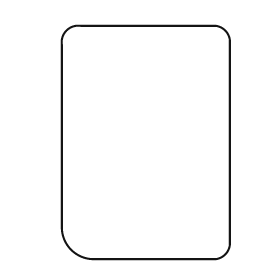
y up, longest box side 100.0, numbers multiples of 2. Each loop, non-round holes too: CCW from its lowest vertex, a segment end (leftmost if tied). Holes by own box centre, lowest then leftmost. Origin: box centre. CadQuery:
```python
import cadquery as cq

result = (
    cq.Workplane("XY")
    .moveTo(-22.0, -50.0)
    .lineTo(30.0, -50.0)
    .threePointArc((34.0, -48.0), (36.0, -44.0))
    .lineTo(36.0, 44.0)
    .threePointArc((34.0, 48.0), (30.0, 50.0))
    .lineTo(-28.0, 50.0)
    .threePointArc((-34.0, 48.0), (-36.0, 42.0))
    .lineTo(-36.0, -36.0)
    .threePointArc((-32.0, -46.0), (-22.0, -50.0))
    .close()
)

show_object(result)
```